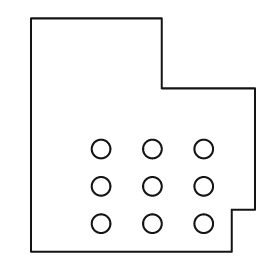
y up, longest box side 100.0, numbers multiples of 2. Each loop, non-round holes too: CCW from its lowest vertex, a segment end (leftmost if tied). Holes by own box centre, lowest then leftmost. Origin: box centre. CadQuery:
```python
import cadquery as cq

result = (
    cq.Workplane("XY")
    .moveTo(-48.0, -50.0)
    .lineTo(38.0, -50.0)
    .lineTo(38.0, -32.0)
    .lineTo(48.0, -32.0)
    .lineTo(48.0, 20.0)
    .lineTo(8.0, 20.0)
    .lineTo(8.0, 50.0)
    .lineTo(-48.0, 50.0)
    .close()
    .moveTo(-18.0, -38.0)
    .circle(4.0)
    .moveTo(4.0, -38.0)
    .circle(4.0)
    .moveTo(26.0, -38.0)
    .circle(4.0)
    .moveTo(-18.0, -22.0)
    .circle(4.0)
    .moveTo(4.0, -22.0)
    .circle(4.0)
    .moveTo(26.0, -22.0)
    .circle(4.0)
    .moveTo(-18.0, -6.0)
    .circle(4.0)
    .moveTo(4.0, -6.0)
    .circle(4.0)
    .moveTo(26.0, -6.0)
    .circle(4.0)
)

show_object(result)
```